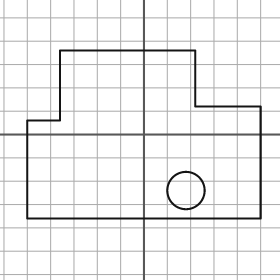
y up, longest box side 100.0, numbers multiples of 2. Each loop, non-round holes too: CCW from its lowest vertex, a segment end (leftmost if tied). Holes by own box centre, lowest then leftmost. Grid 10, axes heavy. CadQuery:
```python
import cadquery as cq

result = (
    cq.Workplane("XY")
    .moveTo(-50.0, -36.0)
    .lineTo(50.0, -36.0)
    .lineTo(50.0, 12.0)
    .lineTo(22.0, 12.0)
    .lineTo(22.0, 36.0)
    .lineTo(-36.0, 36.0)
    .lineTo(-36.0, 6.0)
    .lineTo(-50.0, 6.0)
    .close()
    .moveTo(18.0, -24.0)
    .circle(8.0)
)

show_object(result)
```